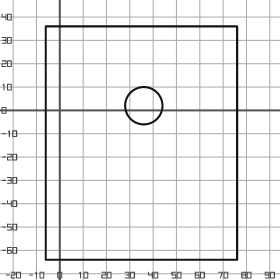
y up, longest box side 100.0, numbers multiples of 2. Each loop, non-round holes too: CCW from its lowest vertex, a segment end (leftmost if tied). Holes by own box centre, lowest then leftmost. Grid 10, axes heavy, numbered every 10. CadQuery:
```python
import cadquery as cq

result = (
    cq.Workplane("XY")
    .moveTo(-6.0, -64.0)
    .lineTo(76.0, -64.0)
    .lineTo(76.0, 36.0)
    .lineTo(-6.0, 36.0)
    .close()
    .moveTo(36.0, 2.0)
    .circle(8.0)
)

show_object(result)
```